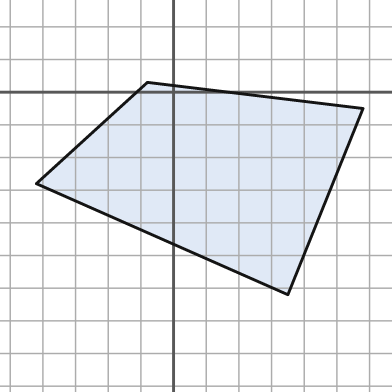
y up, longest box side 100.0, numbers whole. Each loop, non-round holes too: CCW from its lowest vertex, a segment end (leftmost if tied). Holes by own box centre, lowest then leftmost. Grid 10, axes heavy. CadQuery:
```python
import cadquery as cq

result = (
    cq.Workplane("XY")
    .moveTo(35.0, -62.0)
    .lineTo(58.0, -5.0)
    .lineTo(-8.0, 3.0)
    .lineTo(-42.0, -28.0)
    .close()
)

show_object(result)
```